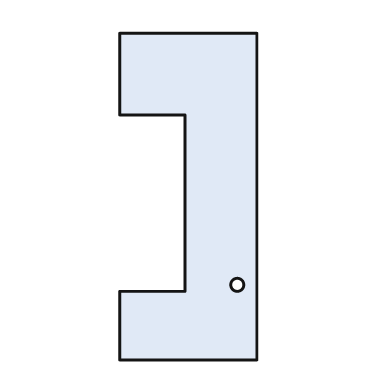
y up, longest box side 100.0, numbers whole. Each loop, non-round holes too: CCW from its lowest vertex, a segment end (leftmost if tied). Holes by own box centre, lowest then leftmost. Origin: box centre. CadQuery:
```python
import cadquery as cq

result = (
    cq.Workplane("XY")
    .moveTo(-21.0, -50.0)
    .lineTo(21.0, -50.0)
    .lineTo(21.0, 50.0)
    .lineTo(-21.0, 50.0)
    .lineTo(-21.0, 25.0)
    .lineTo(-1.0, 25.0)
    .lineTo(-1.0, -29.0)
    .lineTo(-21.0, -29.0)
    .close()
    .moveTo(15.0, -27.0)
    .circle(2.0)
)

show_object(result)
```